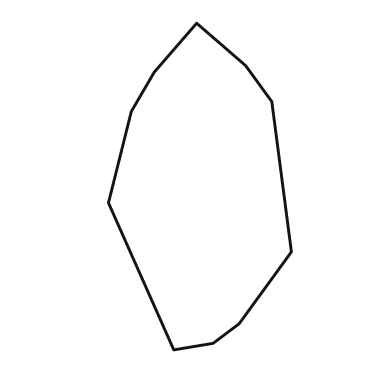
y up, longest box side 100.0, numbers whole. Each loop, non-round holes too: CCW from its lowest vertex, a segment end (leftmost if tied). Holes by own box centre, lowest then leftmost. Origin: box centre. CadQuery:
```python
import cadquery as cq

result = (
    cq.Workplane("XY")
    .moveTo(-8.0, -50.0)
    .lineTo(4.0, -48.0)
    .lineTo(12.0, -42.0)
    .lineTo(28.0, -20.0)
    .lineTo(22.0, 26.0)
    .lineTo(14.0, 37.0)
    .lineTo(-1.0, 50.0)
    .lineTo(-14.0, 35.0)
    .lineTo(-21.0, 23.0)
    .lineTo(-28.0, -5.0)
    .close()
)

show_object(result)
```